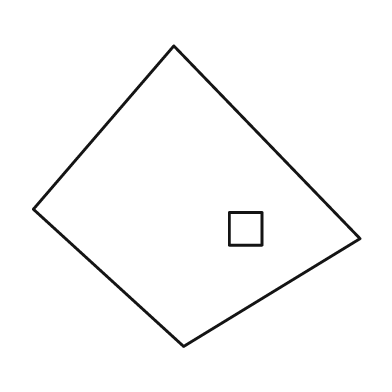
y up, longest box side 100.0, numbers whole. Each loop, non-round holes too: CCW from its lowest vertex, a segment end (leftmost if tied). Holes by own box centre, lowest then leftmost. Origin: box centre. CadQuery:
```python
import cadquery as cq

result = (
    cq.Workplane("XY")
    .moveTo(-4.0, -46.0)
    .lineTo(50.0, -13.0)
    .lineTo(-7.0, 46.0)
    .lineTo(-50.0, -4.0)
    .close()
    .moveTo(10.0, -15.0)
    .lineTo(20.0, -15.0)
    .lineTo(20.0, -5.0)
    .lineTo(10.0, -5.0)
    .close()
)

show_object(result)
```